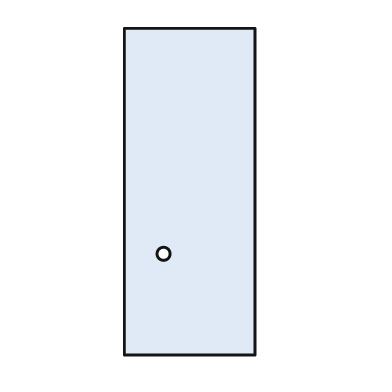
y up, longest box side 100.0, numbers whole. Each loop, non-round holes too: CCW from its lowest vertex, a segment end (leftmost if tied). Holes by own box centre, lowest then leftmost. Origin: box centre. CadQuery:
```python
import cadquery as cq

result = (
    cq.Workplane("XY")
    .moveTo(-20.0, -50.0)
    .lineTo(20.0, -50.0)
    .lineTo(20.0, 50.0)
    .lineTo(-20.0, 50.0)
    .close()
    .moveTo(-8.0, -19.0)
    .circle(2.0)
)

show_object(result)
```